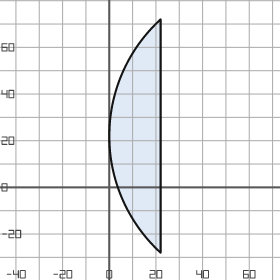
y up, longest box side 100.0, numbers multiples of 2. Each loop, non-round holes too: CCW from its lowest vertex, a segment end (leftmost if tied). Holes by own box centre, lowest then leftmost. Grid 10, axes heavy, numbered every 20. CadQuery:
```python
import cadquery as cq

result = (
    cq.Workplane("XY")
    .moveTo(22.0, -28.0)
    .lineTo(22.0, 72.0)
    .threePointArc((0.0, 22.0), (22.0, -28.0))
    .close()
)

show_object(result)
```